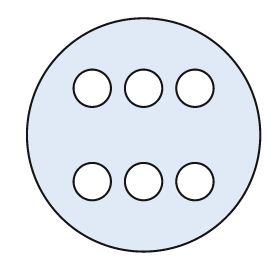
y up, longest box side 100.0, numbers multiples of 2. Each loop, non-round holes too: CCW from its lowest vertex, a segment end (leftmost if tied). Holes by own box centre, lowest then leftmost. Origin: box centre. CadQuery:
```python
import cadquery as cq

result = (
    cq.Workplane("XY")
    .moveTo(0.0, 0.0)
    .circle(50.0)
    .moveTo(-22.0, -20.0)
    .circle(8.0)
    .moveTo(0.0, -20.0)
    .circle(8.0)
    .moveTo(22.0, -20.0)
    .circle(8.0)
    .moveTo(-22.0, 20.0)
    .circle(8.0)
    .moveTo(0.0, 20.0)
    .circle(8.0)
    .moveTo(22.0, 20.0)
    .circle(8.0)
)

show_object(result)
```